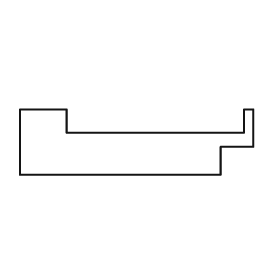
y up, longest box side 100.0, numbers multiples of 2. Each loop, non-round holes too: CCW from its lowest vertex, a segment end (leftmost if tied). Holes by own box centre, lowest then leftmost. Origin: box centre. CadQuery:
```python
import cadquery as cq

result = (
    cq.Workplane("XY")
    .moveTo(-50.0, -14.0)
    .lineTo(36.0, -14.0)
    .lineTo(36.0, -2.0)
    .lineTo(50.0, -2.0)
    .lineTo(50.0, 14.0)
    .lineTo(46.0, 14.0)
    .lineTo(46.0, 4.0)
    .lineTo(-30.0, 4.0)
    .lineTo(-30.0, 14.0)
    .lineTo(-50.0, 14.0)
    .close()
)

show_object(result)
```